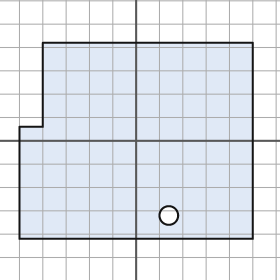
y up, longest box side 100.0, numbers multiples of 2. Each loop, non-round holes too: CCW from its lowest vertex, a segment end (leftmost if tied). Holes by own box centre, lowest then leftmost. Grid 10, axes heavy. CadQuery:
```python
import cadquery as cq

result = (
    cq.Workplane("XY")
    .moveTo(-50.0, -42.0)
    .lineTo(50.0, -42.0)
    .lineTo(50.0, 42.0)
    .lineTo(-40.0, 42.0)
    .lineTo(-40.0, 6.0)
    .lineTo(-50.0, 6.0)
    .close()
    .moveTo(14.0, -32.0)
    .circle(4.0)
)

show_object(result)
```